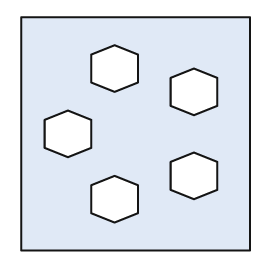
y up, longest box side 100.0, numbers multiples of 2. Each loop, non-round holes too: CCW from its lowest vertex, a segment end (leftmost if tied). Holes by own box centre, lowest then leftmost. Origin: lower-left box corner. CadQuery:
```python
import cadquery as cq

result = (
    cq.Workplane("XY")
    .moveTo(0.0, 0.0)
    .lineTo(98.0, 0.0)
    .lineTo(98.0, 100.0)
    .lineTo(0.0, 100.0)
    .close()
    .moveTo(40.0, 12.0)
    .lineTo(50.0, 16.0)
    .lineTo(50.0, 28.0)
    .lineTo(40.0, 32.0)
    .lineTo(30.0, 28.0)
    .lineTo(30.0, 16.0)
    .close()
    .moveTo(74.0, 22.0)
    .lineTo(84.0, 26.0)
    .lineTo(84.0, 38.0)
    .lineTo(74.0, 42.0)
    .lineTo(64.0, 38.0)
    .lineTo(64.0, 26.0)
    .close()
    .moveTo(20.0, 40.0)
    .lineTo(30.0, 44.0)
    .lineTo(30.0, 56.0)
    .lineTo(20.0, 60.0)
    .lineTo(10.0, 56.0)
    .lineTo(10.0, 44.0)
    .close()
    .moveTo(74.0, 58.0)
    .lineTo(84.0, 62.0)
    .lineTo(84.0, 74.0)
    .lineTo(74.0, 78.0)
    .lineTo(64.0, 74.0)
    .lineTo(64.0, 62.0)
    .close()
    .moveTo(40.0, 68.0)
    .lineTo(50.0, 72.0)
    .lineTo(50.0, 84.0)
    .lineTo(40.0, 88.0)
    .lineTo(30.0, 84.0)
    .lineTo(30.0, 72.0)
    .close()
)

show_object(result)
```